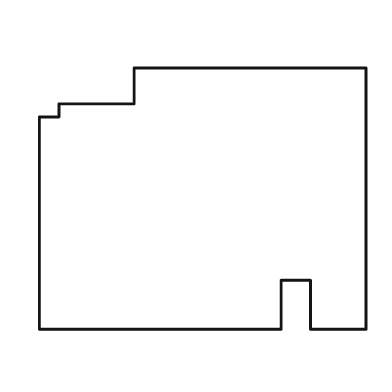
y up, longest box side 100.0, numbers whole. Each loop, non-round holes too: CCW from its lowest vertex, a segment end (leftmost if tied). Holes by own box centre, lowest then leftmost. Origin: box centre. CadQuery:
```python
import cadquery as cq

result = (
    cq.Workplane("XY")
    .moveTo(-50.0, -40.0)
    .lineTo(24.0, -40.0)
    .lineTo(24.0, -25.0)
    .lineTo(33.0, -25.0)
    .lineTo(33.0, -40.0)
    .lineTo(50.0, -40.0)
    .lineTo(50.0, 40.0)
    .lineTo(-21.0, 40.0)
    .lineTo(-21.0, 29.0)
    .lineTo(-44.0, 29.0)
    .lineTo(-44.0, 25.0)
    .lineTo(-50.0, 25.0)
    .close()
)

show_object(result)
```